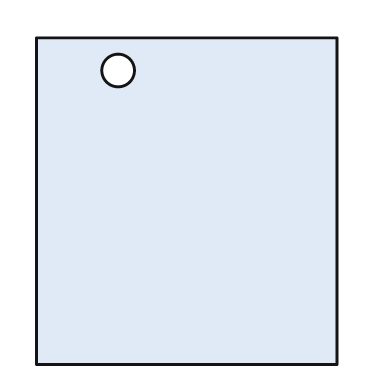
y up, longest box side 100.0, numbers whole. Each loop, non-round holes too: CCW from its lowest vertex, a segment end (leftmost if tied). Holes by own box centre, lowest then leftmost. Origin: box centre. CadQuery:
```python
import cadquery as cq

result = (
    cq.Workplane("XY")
    .moveTo(-46.0, -50.0)
    .lineTo(46.0, -50.0)
    .lineTo(46.0, 50.0)
    .lineTo(-46.0, 50.0)
    .close()
    .moveTo(-21.0, 40.0)
    .circle(5.0)
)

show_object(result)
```